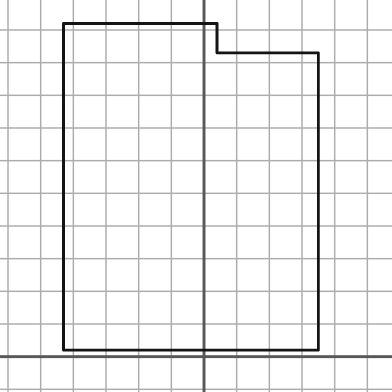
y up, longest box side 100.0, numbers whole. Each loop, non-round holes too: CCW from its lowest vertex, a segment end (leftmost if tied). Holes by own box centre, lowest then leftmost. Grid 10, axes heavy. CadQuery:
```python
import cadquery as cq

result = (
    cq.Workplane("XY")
    .moveTo(-43.0, 2.0)
    .lineTo(35.0, 2.0)
    .lineTo(35.0, 93.0)
    .lineTo(4.0, 93.0)
    .lineTo(4.0, 102.0)
    .lineTo(-43.0, 102.0)
    .close()
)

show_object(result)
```